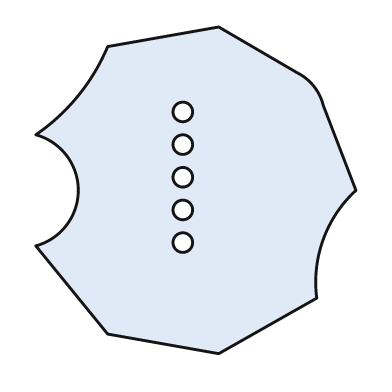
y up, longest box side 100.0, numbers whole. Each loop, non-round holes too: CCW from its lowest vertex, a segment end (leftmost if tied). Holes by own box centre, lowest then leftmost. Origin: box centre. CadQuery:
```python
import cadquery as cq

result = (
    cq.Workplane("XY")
    .moveTo(7.0, -50.0)
    .lineTo(37.0, -33.0)
    .threePointArc((39.0, -15.0), (49.0, 0.0))
    .lineTo(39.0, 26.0)
    .threePointArc((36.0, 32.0), (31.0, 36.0))
    .lineTo(7.0, 50.0)
    .lineTo(-27.0, 44.0)
    .threePointArc((-36.0, 29.0), (-49.0, 17.0))
    .threePointArc((-36.0, 0.0), (-49.0, -17.0))
    .lineTo(-27.0, -44.0)
    .close()
    .moveTo(-4.0, -16.0)
    .circle(3.0)
    .moveTo(-4.0, -6.0)
    .circle(3.0)
    .moveTo(-4.0, 4.0)
    .circle(3.0)
    .moveTo(-4.0, 14.0)
    .circle(3.0)
    .moveTo(-4.0, 24.0)
    .circle(3.0)
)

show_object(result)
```